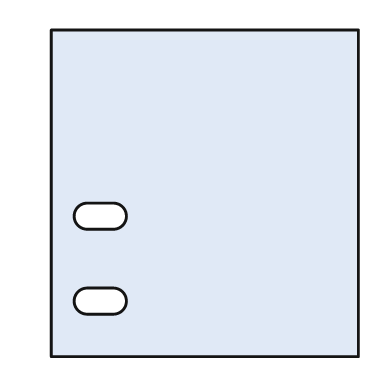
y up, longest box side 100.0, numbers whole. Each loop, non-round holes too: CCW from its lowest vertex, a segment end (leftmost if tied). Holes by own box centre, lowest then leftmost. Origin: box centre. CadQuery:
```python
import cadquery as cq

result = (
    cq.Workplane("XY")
    .moveTo(-47.0, -50.0)
    .lineTo(47.0, -50.0)
    .lineTo(47.0, 50.0)
    .lineTo(-47.0, 50.0)
    .close()
    .moveTo(-36.0, -37.0)
    .lineTo(-28.0, -37.0)
    .threePointArc((-24.0, -33.0), (-28.0, -29.0))
    .lineTo(-36.0, -29.0)
    .threePointArc((-40.0, -33.0), (-36.0, -37.0))
    .close()
    .moveTo(-36.0, -11.0)
    .lineTo(-28.0, -11.0)
    .threePointArc((-24.0, -7.0), (-28.0, -3.0))
    .lineTo(-36.0, -3.0)
    .threePointArc((-40.0, -7.0), (-36.0, -11.0))
    .close()
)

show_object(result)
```